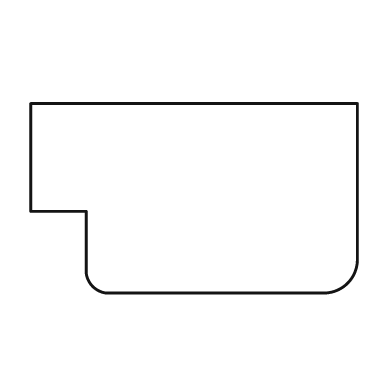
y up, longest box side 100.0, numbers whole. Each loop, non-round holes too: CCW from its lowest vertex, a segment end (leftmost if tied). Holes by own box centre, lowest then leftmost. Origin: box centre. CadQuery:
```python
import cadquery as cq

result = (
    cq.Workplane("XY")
    .moveTo(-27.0, -29.0)
    .lineTo(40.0, -29.0)
    .threePointArc((47.0, -26.0), (50.0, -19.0))
    .lineTo(50.0, 29.0)
    .lineTo(-50.0, 29.0)
    .lineTo(-50.0, -4.0)
    .lineTo(-33.0, -4.0)
    .lineTo(-33.0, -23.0)
    .threePointArc((-31.0, -27.0), (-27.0, -29.0))
    .close()
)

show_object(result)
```